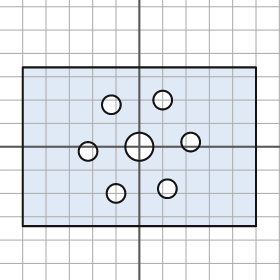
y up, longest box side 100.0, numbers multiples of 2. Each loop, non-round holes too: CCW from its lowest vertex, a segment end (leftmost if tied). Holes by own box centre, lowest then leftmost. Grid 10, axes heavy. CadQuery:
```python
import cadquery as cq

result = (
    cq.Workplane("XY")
    .moveTo(-50.0, -34.0)
    .lineTo(50.0, -34.0)
    .lineTo(50.0, 34.0)
    .lineTo(-50.0, 34.0)
    .close()
    .moveTo(-10.0, -20.0)
    .circle(4.0)
    .moveTo(12.0, -18.0)
    .circle(4.0)
    .moveTo(-22.0, -2.0)
    .circle(4.0)
    .moveTo(0.0, 0.0)
    .circle(6.0)
    .moveTo(22.0, 2.0)
    .circle(4.0)
    .moveTo(-12.0, 18.0)
    .circle(4.0)
    .moveTo(10.0, 20.0)
    .circle(4.0)
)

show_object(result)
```